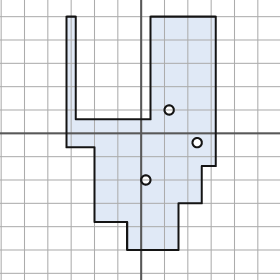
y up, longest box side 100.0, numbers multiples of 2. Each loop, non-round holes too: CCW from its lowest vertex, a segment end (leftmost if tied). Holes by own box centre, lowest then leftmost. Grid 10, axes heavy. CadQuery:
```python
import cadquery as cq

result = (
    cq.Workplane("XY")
    .moveTo(-6.0, -50.0)
    .lineTo(16.0, -50.0)
    .lineTo(16.0, -30.0)
    .lineTo(26.0, -30.0)
    .lineTo(26.0, -14.0)
    .lineTo(32.0, -14.0)
    .lineTo(32.0, 50.0)
    .lineTo(4.0, 50.0)
    .lineTo(4.0, 6.0)
    .lineTo(-28.0, 6.0)
    .lineTo(-28.0, 50.0)
    .lineTo(-32.0, 50.0)
    .lineTo(-32.0, -6.0)
    .lineTo(-20.0, -6.0)
    .lineTo(-20.0, -38.0)
    .lineTo(-6.0, -38.0)
    .close()
    .moveTo(2.0, -20.0)
    .circle(2.0)
    .moveTo(24.0, -4.0)
    .circle(2.0)
    .moveTo(12.0, 10.0)
    .circle(2.0)
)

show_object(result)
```